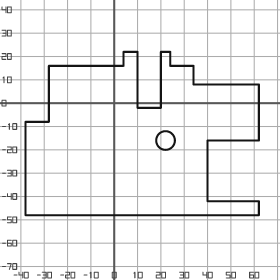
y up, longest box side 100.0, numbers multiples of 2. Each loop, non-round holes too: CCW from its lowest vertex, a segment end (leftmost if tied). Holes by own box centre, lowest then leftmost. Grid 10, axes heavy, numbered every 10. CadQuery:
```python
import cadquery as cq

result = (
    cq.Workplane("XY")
    .moveTo(-38.0, -48.0)
    .lineTo(62.0, -48.0)
    .lineTo(62.0, -42.0)
    .lineTo(40.0, -42.0)
    .lineTo(40.0, -16.0)
    .lineTo(62.0, -16.0)
    .lineTo(62.0, 8.0)
    .lineTo(34.0, 8.0)
    .lineTo(34.0, 16.0)
    .lineTo(24.0, 16.0)
    .lineTo(24.0, 22.0)
    .lineTo(20.0, 22.0)
    .lineTo(20.0, -2.0)
    .lineTo(10.0, -2.0)
    .lineTo(10.0, 22.0)
    .lineTo(4.0, 22.0)
    .lineTo(4.0, 16.0)
    .lineTo(-28.0, 16.0)
    .lineTo(-28.0, -8.0)
    .lineTo(-38.0, -8.0)
    .close()
    .moveTo(22.0, -16.0)
    .circle(4.0)
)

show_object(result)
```